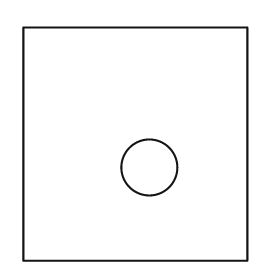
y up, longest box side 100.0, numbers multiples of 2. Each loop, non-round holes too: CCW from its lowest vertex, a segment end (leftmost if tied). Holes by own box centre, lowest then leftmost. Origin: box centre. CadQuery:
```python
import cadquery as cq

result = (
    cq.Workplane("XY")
    .moveTo(-48.0, -50.0)
    .lineTo(48.0, -50.0)
    .lineTo(48.0, 50.0)
    .lineTo(-48.0, 50.0)
    .close()
    .moveTo(6.0, -10.0)
    .circle(12.0)
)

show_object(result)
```